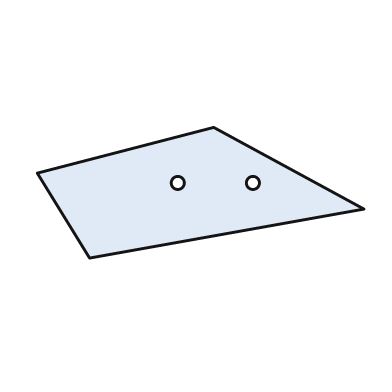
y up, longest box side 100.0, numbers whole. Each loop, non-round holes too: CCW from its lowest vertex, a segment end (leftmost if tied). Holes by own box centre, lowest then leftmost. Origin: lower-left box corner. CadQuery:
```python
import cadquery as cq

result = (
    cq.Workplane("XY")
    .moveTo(16.0, 0.0)
    .lineTo(100.0, 15.0)
    .lineTo(54.0, 40.0)
    .lineTo(0.0, 26.0)
    .close()
    .moveTo(43.0, 23.0)
    .circle(2.0)
    .moveTo(66.0, 23.0)
    .circle(2.0)
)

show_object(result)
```